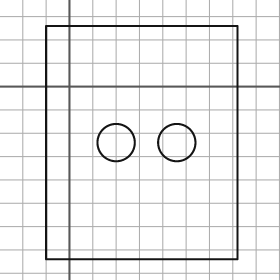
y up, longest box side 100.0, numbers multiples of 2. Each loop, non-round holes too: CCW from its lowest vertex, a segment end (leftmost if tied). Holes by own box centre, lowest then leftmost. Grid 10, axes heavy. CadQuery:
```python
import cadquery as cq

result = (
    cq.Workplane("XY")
    .moveTo(-10.0, -74.0)
    .lineTo(72.0, -74.0)
    .lineTo(72.0, 26.0)
    .lineTo(-10.0, 26.0)
    .close()
    .moveTo(20.0, -24.0)
    .circle(8.0)
    .moveTo(46.0, -24.0)
    .circle(8.0)
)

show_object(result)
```